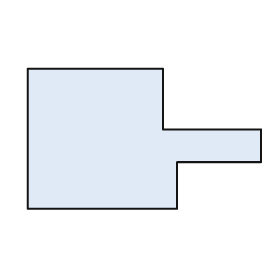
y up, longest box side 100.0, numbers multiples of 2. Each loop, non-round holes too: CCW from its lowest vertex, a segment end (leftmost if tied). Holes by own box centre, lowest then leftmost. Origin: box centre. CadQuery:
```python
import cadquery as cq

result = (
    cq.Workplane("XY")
    .moveTo(-50.0, -30.0)
    .lineTo(14.0, -30.0)
    .lineTo(14.0, -10.0)
    .lineTo(50.0, -10.0)
    .lineTo(50.0, 4.0)
    .lineTo(8.0, 4.0)
    .lineTo(8.0, 30.0)
    .lineTo(-50.0, 30.0)
    .close()
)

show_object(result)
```